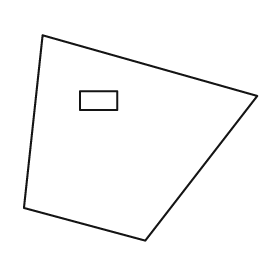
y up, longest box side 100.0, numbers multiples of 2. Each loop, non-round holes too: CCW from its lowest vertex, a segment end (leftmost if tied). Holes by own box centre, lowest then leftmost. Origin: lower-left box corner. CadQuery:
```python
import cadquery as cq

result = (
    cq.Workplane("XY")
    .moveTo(52.0, 0.0)
    .lineTo(100.0, 62.0)
    .lineTo(8.0, 88.0)
    .lineTo(0.0, 14.0)
    .close()
    .moveTo(24.0, 56.0)
    .lineTo(40.0, 56.0)
    .lineTo(40.0, 64.0)
    .lineTo(24.0, 64.0)
    .close()
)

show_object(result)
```